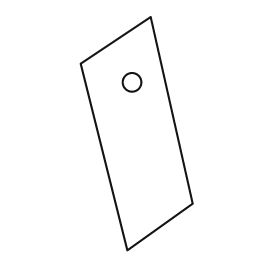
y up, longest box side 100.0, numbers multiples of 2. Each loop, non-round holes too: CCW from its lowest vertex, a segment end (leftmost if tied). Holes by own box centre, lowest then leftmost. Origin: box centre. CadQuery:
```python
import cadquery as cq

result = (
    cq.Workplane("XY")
    .moveTo(-4.0, -50.0)
    .lineTo(24.0, -30.0)
    .lineTo(6.0, 50.0)
    .lineTo(-24.0, 30.0)
    .close()
    .moveTo(-2.0, 22.0)
    .circle(4.0)
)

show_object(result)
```